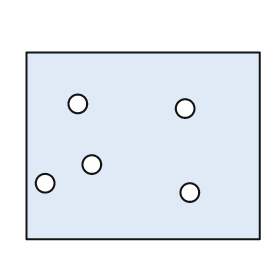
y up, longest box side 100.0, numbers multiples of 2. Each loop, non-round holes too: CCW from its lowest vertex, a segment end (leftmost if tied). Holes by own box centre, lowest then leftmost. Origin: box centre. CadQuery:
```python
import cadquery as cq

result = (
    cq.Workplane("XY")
    .moveTo(-50.0, -40.0)
    .lineTo(50.0, -40.0)
    .lineTo(50.0, 40.0)
    .lineTo(-50.0, 40.0)
    .close()
    .moveTo(20.0, -20.0)
    .circle(4.0)
    .moveTo(-42.0, -16.0)
    .circle(4.0)
    .moveTo(-22.0, -8.0)
    .circle(4.0)
    .moveTo(18.0, 16.0)
    .circle(4.0)
    .moveTo(-28.0, 18.0)
    .circle(4.0)
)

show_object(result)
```